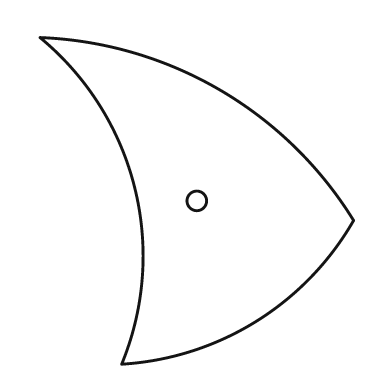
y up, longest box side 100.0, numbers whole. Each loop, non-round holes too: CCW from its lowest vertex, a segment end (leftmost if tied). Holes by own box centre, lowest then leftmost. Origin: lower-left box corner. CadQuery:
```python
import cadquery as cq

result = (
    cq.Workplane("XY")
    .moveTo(25.0, 0.0)
    .threePointArc((66.0, 13.0), (96.0, 44.0))
    .threePointArc((55.0, 84.0), (0.0, 100.0))
    .threePointArc((29.0, 54.0), (25.0, 0.0))
    .close()
    .moveTo(48.0, 50.0)
    .circle(3.0)
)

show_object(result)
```